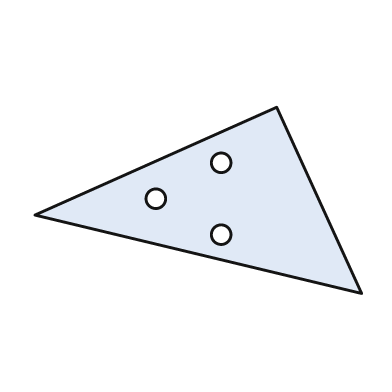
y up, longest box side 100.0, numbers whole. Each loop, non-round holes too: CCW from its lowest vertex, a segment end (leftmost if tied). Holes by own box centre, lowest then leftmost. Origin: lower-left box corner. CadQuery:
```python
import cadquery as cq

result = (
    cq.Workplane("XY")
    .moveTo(100.0, 0.0)
    .lineTo(74.0, 57.0)
    .lineTo(0.0, 24.0)
    .close()
    .moveTo(57.0, 18.0)
    .circle(3.0)
    .moveTo(37.0, 29.0)
    .circle(3.0)
    .moveTo(57.0, 40.0)
    .circle(3.0)
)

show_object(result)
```